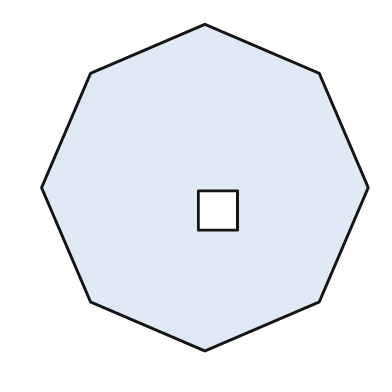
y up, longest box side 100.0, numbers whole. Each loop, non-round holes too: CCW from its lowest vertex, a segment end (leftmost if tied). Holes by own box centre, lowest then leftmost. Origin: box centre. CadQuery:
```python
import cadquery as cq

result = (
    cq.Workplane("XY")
    .moveTo(0.0, -50.0)
    .lineTo(35.0, -35.0)
    .lineTo(50.0, 0.0)
    .lineTo(35.0, 35.0)
    .lineTo(0.0, 50.0)
    .lineTo(-35.0, 35.0)
    .lineTo(-50.0, 0.0)
    .lineTo(-35.0, -35.0)
    .close()
    .moveTo(-2.0, -13.0)
    .lineTo(10.0, -13.0)
    .lineTo(10.0, -1.0)
    .lineTo(-2.0, -1.0)
    .close()
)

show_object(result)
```